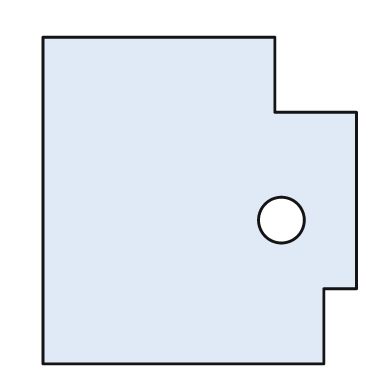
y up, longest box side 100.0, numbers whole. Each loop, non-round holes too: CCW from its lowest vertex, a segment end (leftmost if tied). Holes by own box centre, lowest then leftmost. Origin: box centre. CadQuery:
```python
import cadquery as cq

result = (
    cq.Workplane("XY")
    .moveTo(-48.0, -50.0)
    .lineTo(38.0, -50.0)
    .lineTo(38.0, -27.0)
    .lineTo(48.0, -27.0)
    .lineTo(48.0, 27.0)
    .lineTo(23.0, 27.0)
    .lineTo(23.0, 50.0)
    .lineTo(-48.0, 50.0)
    .close()
    .moveTo(25.0, -6.0)
    .circle(7.0)
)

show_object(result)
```